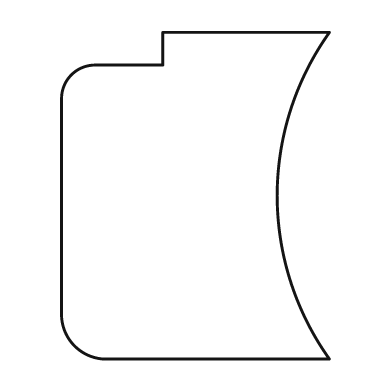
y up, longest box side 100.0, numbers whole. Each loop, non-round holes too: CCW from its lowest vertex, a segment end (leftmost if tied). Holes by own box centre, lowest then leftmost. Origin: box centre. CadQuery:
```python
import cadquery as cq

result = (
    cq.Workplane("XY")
    .moveTo(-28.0, -50.0)
    .lineTo(41.0, -50.0)
    .threePointArc((25.0, 0.0), (41.0, 50.0))
    .lineTo(-10.0, 50.0)
    .lineTo(-10.0, 40.0)
    .lineTo(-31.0, 40.0)
    .threePointArc((-38.0, 37.0), (-41.0, 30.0))
    .lineTo(-41.0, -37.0)
    .threePointArc((-37.0, -46.0), (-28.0, -50.0))
    .close()
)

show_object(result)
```